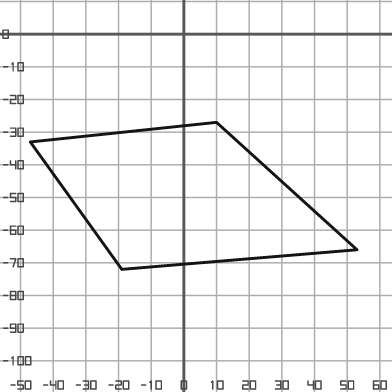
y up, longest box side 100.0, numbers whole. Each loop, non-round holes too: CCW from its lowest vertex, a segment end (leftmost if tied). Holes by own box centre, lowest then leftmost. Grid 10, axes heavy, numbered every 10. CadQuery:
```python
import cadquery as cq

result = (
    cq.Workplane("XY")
    .moveTo(-19.0, -72.0)
    .lineTo(53.0, -66.0)
    .lineTo(10.0, -27.0)
    .lineTo(-47.0, -33.0)
    .close()
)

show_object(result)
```